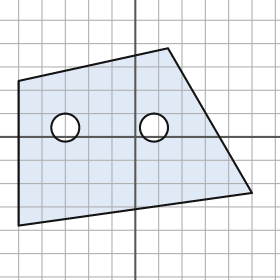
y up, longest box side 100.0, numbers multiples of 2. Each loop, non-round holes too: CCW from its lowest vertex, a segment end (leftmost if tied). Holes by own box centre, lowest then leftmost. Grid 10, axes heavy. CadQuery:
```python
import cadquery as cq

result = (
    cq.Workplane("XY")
    .moveTo(-50.0, -38.0)
    .lineTo(50.0, -24.0)
    .lineTo(14.0, 38.0)
    .lineTo(-50.0, 24.0)
    .close()
    .moveTo(-30.0, 4.0)
    .circle(6.0)
    .moveTo(8.0, 4.0)
    .circle(6.0)
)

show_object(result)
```